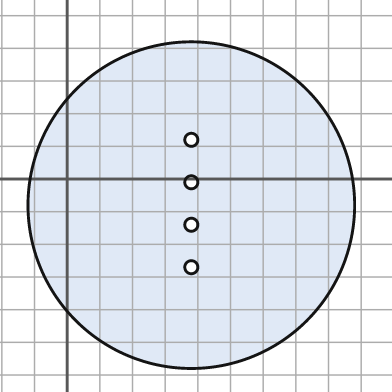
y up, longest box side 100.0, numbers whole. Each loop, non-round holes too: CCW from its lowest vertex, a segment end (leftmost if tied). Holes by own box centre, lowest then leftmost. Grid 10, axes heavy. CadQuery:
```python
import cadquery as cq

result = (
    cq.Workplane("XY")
    .moveTo(38.0, -8.0)
    .circle(50.0)
    .moveTo(38.0, -27.0)
    .circle(2.0)
    .moveTo(38.0, -14.0)
    .circle(2.0)
    .moveTo(38.0, -1.0)
    .circle(2.0)
    .moveTo(38.0, 12.0)
    .circle(2.0)
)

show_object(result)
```